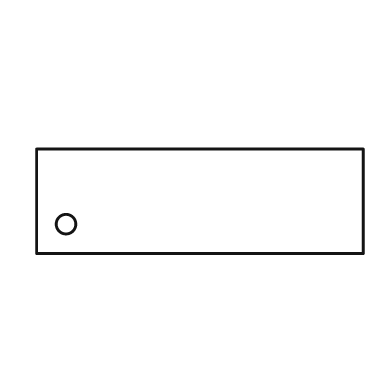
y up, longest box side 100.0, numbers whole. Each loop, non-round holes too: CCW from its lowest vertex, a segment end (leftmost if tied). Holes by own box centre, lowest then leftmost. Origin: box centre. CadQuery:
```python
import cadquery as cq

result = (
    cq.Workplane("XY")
    .moveTo(-50.0, -16.0)
    .lineTo(50.0, -16.0)
    .lineTo(50.0, 16.0)
    .lineTo(-50.0, 16.0)
    .close()
    .moveTo(-41.0, -7.0)
    .circle(3.0)
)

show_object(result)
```